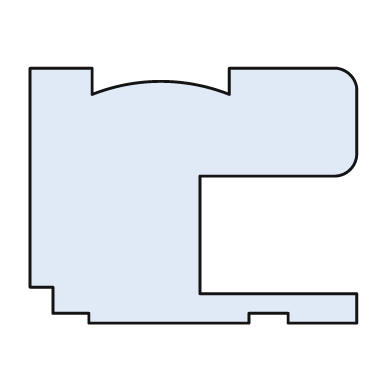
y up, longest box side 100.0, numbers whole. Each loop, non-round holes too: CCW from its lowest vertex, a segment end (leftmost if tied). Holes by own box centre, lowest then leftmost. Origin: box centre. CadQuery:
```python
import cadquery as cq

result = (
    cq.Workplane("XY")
    .moveTo(-32.0, -39.0)
    .lineTo(17.0, -39.0)
    .lineTo(17.0, -36.0)
    .lineTo(29.0, -36.0)
    .lineTo(29.0, -39.0)
    .lineTo(50.0, -39.0)
    .lineTo(50.0, -30.0)
    .lineTo(2.0, -30.0)
    .lineTo(2.0, 6.0)
    .lineTo(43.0, 6.0)
    .threePointArc((48.0, 8.0), (50.0, 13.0))
    .lineTo(50.0, 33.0)
    .threePointArc((48.0, 37.0), (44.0, 39.0))
    .lineTo(11.0, 39.0)
    .lineTo(11.0, 31.0)
    .threePointArc((-10.0, 35.0), (-31.0, 31.0))
    .lineTo(-31.0, 39.0)
    .lineTo(-50.0, 39.0)
    .lineTo(-50.0, -28.0)
    .lineTo(-43.0, -28.0)
    .lineTo(-43.0, -36.0)
    .lineTo(-32.0, -36.0)
    .close()
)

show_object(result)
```